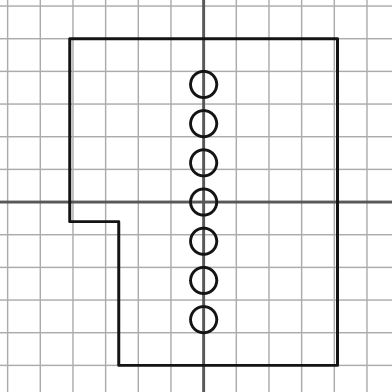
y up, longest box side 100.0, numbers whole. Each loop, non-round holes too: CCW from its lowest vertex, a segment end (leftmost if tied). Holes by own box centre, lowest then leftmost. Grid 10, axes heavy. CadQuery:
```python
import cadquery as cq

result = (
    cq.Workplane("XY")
    .moveTo(-26.0, -50.0)
    .lineTo(41.0, -50.0)
    .lineTo(41.0, 50.0)
    .lineTo(-41.0, 50.0)
    .lineTo(-41.0, -6.0)
    .lineTo(-26.0, -6.0)
    .close()
    .moveTo(0.0, -36.0)
    .circle(4.0)
    .moveTo(0.0, -24.0)
    .circle(4.0)
    .moveTo(0.0, -12.0)
    .circle(4.0)
    .moveTo(0.0, 0.0)
    .circle(4.0)
    .moveTo(0.0, 12.0)
    .circle(4.0)
    .moveTo(0.0, 24.0)
    .circle(4.0)
    .moveTo(0.0, 36.0)
    .circle(4.0)
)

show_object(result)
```